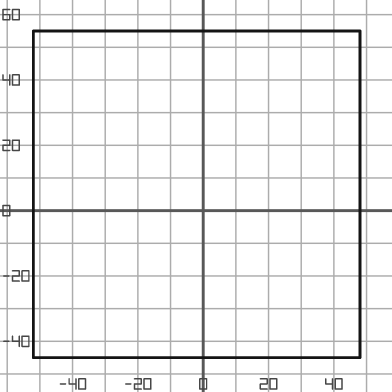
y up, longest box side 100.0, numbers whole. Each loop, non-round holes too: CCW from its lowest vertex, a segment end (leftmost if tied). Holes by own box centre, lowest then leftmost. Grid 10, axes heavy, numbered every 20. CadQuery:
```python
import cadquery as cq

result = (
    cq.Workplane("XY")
    .moveTo(-52.0, -45.0)
    .lineTo(48.0, -45.0)
    .lineTo(48.0, 55.0)
    .lineTo(-52.0, 55.0)
    .close()
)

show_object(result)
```